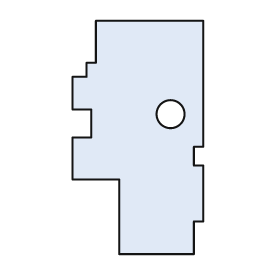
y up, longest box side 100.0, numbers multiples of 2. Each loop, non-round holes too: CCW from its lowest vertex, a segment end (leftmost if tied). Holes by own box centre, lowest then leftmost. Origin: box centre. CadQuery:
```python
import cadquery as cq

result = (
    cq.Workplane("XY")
    .moveTo(-8.0, -50.0)
    .lineTo(24.0, -50.0)
    .lineTo(24.0, -36.0)
    .lineTo(28.0, -36.0)
    .lineTo(28.0, -12.0)
    .lineTo(24.0, -12.0)
    .lineTo(24.0, -4.0)
    .lineTo(28.0, -4.0)
    .lineTo(28.0, 50.0)
    .lineTo(-18.0, 50.0)
    .lineTo(-18.0, 32.0)
    .lineTo(-22.0, 32.0)
    .lineTo(-22.0, 26.0)
    .lineTo(-28.0, 26.0)
    .lineTo(-28.0, 12.0)
    .lineTo(-20.0, 12.0)
    .lineTo(-20.0, 0.0)
    .lineTo(-28.0, 0.0)
    .lineTo(-28.0, -18.0)
    .lineTo(-8.0, -18.0)
    .close()
    .moveTo(14.0, 10.0)
    .circle(6.0)
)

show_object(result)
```